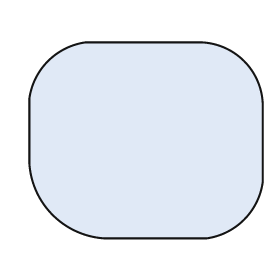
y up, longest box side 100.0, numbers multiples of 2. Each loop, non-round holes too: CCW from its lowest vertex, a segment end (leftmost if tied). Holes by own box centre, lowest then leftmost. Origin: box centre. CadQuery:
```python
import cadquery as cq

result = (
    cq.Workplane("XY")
    .moveTo(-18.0, -42.0)
    .lineTo(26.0, -42.0)
    .threePointArc((42.0, -34.0), (50.0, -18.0))
    .lineTo(50.0, 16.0)
    .threePointArc((42.0, 34.0), (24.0, 42.0))
    .lineTo(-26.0, 42.0)
    .threePointArc((-42.0, 34.0), (-50.0, 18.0))
    .lineTo(-50.0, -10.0)
    .threePointArc((-40.0, -32.0), (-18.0, -42.0))
    .close()
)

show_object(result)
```